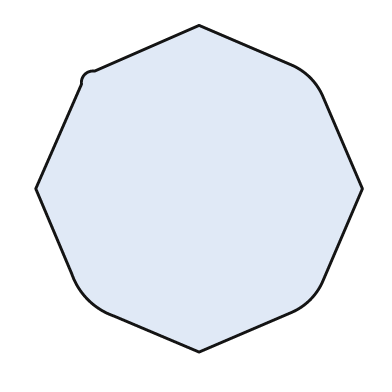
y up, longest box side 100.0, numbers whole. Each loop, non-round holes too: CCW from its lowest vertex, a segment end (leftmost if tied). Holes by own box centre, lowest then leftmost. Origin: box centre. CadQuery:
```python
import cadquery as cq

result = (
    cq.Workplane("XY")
    .moveTo(0.0, -50.0)
    .lineTo(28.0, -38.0)
    .threePointArc((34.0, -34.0), (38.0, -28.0))
    .lineTo(50.0, 0.0)
    .lineTo(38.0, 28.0)
    .threePointArc((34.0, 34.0), (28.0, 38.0))
    .lineTo(0.0, 50.0)
    .lineTo(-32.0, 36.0)
    .threePointArc((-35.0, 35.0), (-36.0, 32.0))
    .lineTo(-50.0, 0.0)
    .lineTo(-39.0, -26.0)
    .threePointArc((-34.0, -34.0), (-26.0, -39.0))
    .close()
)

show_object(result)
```